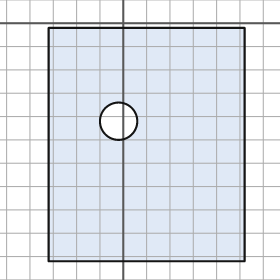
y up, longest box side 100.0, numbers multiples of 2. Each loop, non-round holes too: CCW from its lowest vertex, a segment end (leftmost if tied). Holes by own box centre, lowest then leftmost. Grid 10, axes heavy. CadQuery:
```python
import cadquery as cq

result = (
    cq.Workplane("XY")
    .moveTo(-32.0, -102.0)
    .lineTo(52.0, -102.0)
    .lineTo(52.0, -2.0)
    .lineTo(-32.0, -2.0)
    .close()
    .moveTo(-2.0, -42.0)
    .circle(8.0)
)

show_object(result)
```